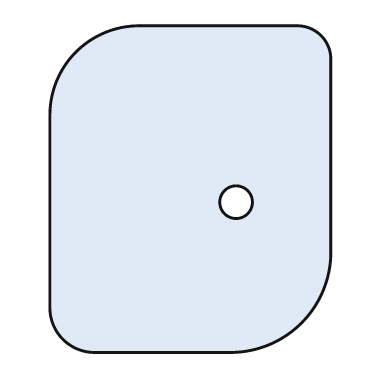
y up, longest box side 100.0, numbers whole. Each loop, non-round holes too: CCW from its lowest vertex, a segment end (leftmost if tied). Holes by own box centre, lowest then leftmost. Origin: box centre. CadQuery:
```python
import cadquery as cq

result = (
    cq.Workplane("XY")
    .moveTo(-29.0, -50.0)
    .lineTo(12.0, -50.0)
    .threePointArc((34.0, -41.0), (43.0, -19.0))
    .lineTo(43.0, 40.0)
    .threePointArc((40.0, 47.0), (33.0, 50.0))
    .lineTo(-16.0, 50.0)
    .threePointArc((-35.0, 42.0), (-43.0, 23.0))
    .lineTo(-43.0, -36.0)
    .threePointArc((-39.0, -46.0), (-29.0, -50.0))
    .close()
    .moveTo(14.0, -4.0)
    .circle(5.0)
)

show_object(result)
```